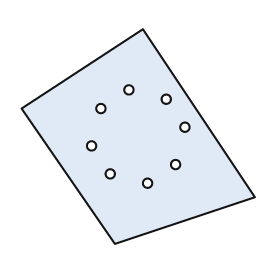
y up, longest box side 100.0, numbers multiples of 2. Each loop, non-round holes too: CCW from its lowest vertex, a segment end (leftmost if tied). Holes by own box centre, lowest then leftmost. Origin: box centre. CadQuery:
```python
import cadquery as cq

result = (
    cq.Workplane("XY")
    .moveTo(-10.0, -46.0)
    .lineTo(50.0, -26.0)
    .lineTo(2.0, 46.0)
    .lineTo(-50.0, 12.0)
    .close()
    .moveTo(4.0, -20.0)
    .circle(2.0)
    .moveTo(-12.0, -16.0)
    .circle(2.0)
    .moveTo(16.0, -12.0)
    .circle(2.0)
    .moveTo(-20.0, -4.0)
    .circle(2.0)
    .moveTo(20.0, 4.0)
    .circle(2.0)
    .moveTo(-16.0, 12.0)
    .circle(2.0)
    .moveTo(12.0, 16.0)
    .circle(2.0)
    .moveTo(-4.0, 20.0)
    .circle(2.0)
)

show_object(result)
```